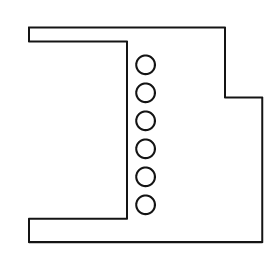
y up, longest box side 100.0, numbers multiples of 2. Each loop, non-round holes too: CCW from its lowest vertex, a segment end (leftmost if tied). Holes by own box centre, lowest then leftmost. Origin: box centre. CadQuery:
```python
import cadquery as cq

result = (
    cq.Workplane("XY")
    .moveTo(-50.0, -46.0)
    .lineTo(50.0, -46.0)
    .lineTo(50.0, 16.0)
    .lineTo(34.0, 16.0)
    .lineTo(34.0, 46.0)
    .lineTo(-50.0, 46.0)
    .lineTo(-50.0, 40.0)
    .lineTo(-8.0, 40.0)
    .lineTo(-8.0, -36.0)
    .lineTo(-50.0, -36.0)
    .close()
    .moveTo(0.0, -30.0)
    .circle(4.0)
    .moveTo(0.0, -18.0)
    .circle(4.0)
    .moveTo(0.0, -6.0)
    .circle(4.0)
    .moveTo(0.0, 6.0)
    .circle(4.0)
    .moveTo(0.0, 18.0)
    .circle(4.0)
    .moveTo(0.0, 30.0)
    .circle(4.0)
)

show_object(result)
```